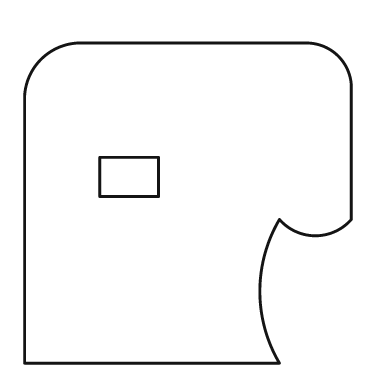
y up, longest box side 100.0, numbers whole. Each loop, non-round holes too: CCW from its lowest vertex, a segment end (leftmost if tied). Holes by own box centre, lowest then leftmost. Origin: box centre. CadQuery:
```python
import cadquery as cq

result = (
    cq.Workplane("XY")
    .moveTo(-50.0, -49.0)
    .lineTo(28.0, -49.0)
    .threePointArc((22.0, -27.0), (28.0, -5.0))
    .threePointArc((39.0, -10.0), (50.0, -5.0))
    .lineTo(50.0, 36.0)
    .threePointArc((46.0, 45.0), (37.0, 49.0))
    .lineTo(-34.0, 49.0)
    .threePointArc((-45.0, 44.0), (-50.0, 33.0))
    .close()
    .moveTo(-27.0, 2.0)
    .lineTo(-9.0, 2.0)
    .lineTo(-9.0, 14.0)
    .lineTo(-27.0, 14.0)
    .close()
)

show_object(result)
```